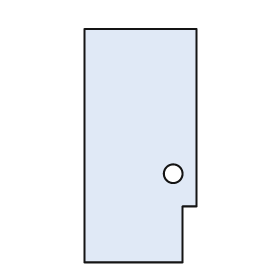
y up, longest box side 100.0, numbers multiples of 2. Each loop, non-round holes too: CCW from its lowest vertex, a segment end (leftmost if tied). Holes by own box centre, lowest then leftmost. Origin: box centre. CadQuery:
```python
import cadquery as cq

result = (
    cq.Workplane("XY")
    .moveTo(-24.0, -50.0)
    .lineTo(18.0, -50.0)
    .lineTo(18.0, -26.0)
    .lineTo(24.0, -26.0)
    .lineTo(24.0, 50.0)
    .lineTo(-24.0, 50.0)
    .close()
    .moveTo(14.0, -12.0)
    .circle(4.0)
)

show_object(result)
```